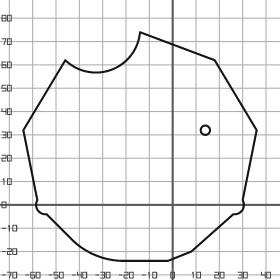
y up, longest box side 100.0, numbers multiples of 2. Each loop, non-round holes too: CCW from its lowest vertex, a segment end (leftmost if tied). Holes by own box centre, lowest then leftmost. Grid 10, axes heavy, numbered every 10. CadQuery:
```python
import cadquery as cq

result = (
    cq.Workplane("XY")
    .moveTo(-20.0, -24.0)
    .lineTo(-2.0, -24.0)
    .lineTo(8.0, -20.0)
    .lineTo(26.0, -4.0)
    .threePointArc((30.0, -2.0), (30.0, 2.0))
    .lineTo(36.0, 32.0)
    .lineTo(18.0, 62.0)
    .lineTo(-14.0, 74.0)
    .threePointArc((-26.0, 58.0), (-46.0, 62.0))
    .lineTo(-64.0, 32.0)
    .lineTo(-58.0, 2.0)
    .threePointArc((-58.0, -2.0), (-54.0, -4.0))
    .lineTo(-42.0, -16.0)
    .threePointArc((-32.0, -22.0), (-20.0, -24.0))
    .close()
    .moveTo(14.0, 32.0)
    .circle(2.0)
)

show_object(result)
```